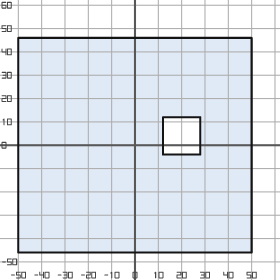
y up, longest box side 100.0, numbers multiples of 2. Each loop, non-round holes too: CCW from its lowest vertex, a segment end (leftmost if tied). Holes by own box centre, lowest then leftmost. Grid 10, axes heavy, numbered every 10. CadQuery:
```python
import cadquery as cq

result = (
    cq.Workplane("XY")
    .moveTo(-50.0, -46.0)
    .lineTo(50.0, -46.0)
    .lineTo(50.0, 46.0)
    .lineTo(-50.0, 46.0)
    .close()
    .moveTo(12.0, -4.0)
    .lineTo(28.0, -4.0)
    .lineTo(28.0, 12.0)
    .lineTo(12.0, 12.0)
    .close()
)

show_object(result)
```